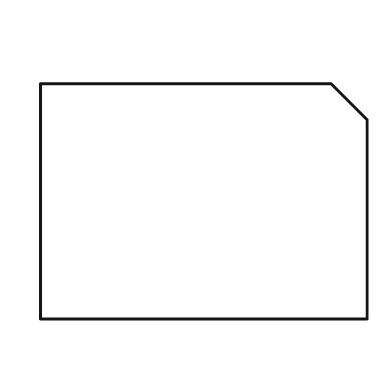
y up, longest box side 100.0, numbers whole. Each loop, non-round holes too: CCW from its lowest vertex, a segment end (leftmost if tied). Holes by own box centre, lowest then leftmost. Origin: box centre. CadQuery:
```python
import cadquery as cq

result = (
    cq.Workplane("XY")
    .moveTo(-50.0, -36.0)
    .lineTo(50.0, -36.0)
    .lineTo(50.0, 25.0)
    .lineTo(39.0, 36.0)
    .lineTo(-50.0, 36.0)
    .close()
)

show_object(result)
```